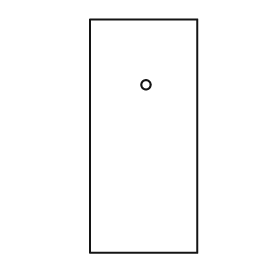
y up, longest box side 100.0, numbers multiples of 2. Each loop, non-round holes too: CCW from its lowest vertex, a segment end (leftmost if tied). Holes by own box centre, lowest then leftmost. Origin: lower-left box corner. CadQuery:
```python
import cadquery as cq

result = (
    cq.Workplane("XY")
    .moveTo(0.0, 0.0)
    .lineTo(46.0, 0.0)
    .lineTo(46.0, 100.0)
    .lineTo(0.0, 100.0)
    .close()
    .moveTo(24.0, 72.0)
    .circle(2.0)
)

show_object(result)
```